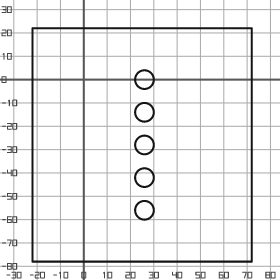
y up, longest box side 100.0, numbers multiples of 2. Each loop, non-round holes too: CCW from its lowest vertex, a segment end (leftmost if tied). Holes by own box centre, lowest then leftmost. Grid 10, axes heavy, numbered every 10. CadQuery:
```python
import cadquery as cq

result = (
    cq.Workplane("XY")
    .moveTo(-22.0, -78.0)
    .lineTo(72.0, -78.0)
    .lineTo(72.0, 22.0)
    .lineTo(-22.0, 22.0)
    .close()
    .moveTo(26.0, -56.0)
    .circle(4.0)
    .moveTo(26.0, -42.0)
    .circle(4.0)
    .moveTo(26.0, -28.0)
    .circle(4.0)
    .moveTo(26.0, -14.0)
    .circle(4.0)
    .moveTo(26.0, 0.0)
    .circle(4.0)
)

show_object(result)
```